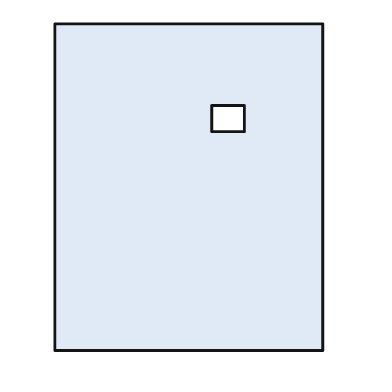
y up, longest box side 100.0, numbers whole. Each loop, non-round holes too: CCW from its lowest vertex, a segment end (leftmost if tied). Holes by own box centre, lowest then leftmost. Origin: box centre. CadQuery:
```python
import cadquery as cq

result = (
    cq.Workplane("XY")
    .moveTo(-41.0, -50.0)
    .lineTo(41.0, -50.0)
    .lineTo(41.0, 50.0)
    .lineTo(-41.0, 50.0)
    .close()
    .moveTo(7.0, 17.0)
    .lineTo(17.0, 17.0)
    .lineTo(17.0, 25.0)
    .lineTo(7.0, 25.0)
    .close()
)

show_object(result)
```